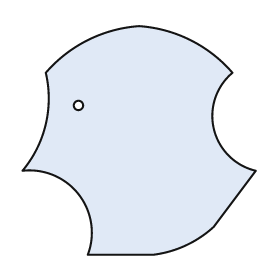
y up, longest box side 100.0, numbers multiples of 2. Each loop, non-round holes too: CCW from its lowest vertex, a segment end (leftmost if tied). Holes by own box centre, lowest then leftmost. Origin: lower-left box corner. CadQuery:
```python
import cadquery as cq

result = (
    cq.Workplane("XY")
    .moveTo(28.0, 0.0)
    .lineTo(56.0, 0.0)
    .threePointArc((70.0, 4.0), (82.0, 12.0))
    .lineTo(100.0, 36.0)
    .threePointArc((82.0, 54.0), (90.0, 78.0))
    .threePointArc((72.0, 92.0), (50.0, 98.0))
    .threePointArc((28.0, 92.0), (10.0, 78.0))
    .threePointArc((10.0, 56.0), (0.0, 36.0))
    .threePointArc((24.0, 26.0), (28.0, 0.0))
    .close()
    .moveTo(24.0, 64.0)
    .circle(2.0)
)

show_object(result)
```